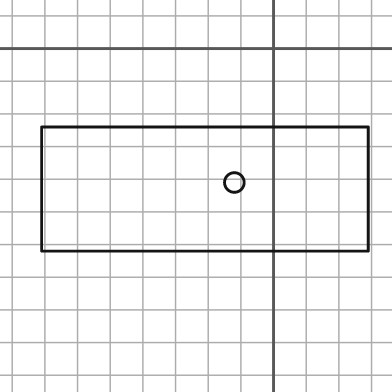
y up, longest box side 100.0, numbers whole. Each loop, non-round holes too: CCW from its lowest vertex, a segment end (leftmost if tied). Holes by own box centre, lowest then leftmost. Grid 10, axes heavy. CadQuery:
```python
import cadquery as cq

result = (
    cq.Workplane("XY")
    .moveTo(-71.0, -62.0)
    .lineTo(29.0, -62.0)
    .lineTo(29.0, -24.0)
    .lineTo(-71.0, -24.0)
    .close()
    .moveTo(-12.0, -41.0)
    .circle(3.0)
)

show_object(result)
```